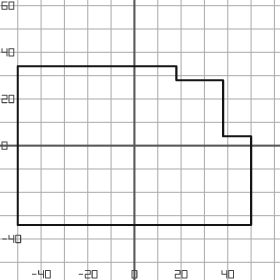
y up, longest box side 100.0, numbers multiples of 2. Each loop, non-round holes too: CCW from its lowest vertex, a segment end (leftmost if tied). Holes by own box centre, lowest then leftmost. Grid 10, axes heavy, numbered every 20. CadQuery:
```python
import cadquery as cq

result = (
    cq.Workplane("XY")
    .moveTo(-50.0, -34.0)
    .lineTo(50.0, -34.0)
    .lineTo(50.0, 4.0)
    .lineTo(38.0, 4.0)
    .lineTo(38.0, 28.0)
    .lineTo(18.0, 28.0)
    .lineTo(18.0, 34.0)
    .lineTo(-50.0, 34.0)
    .close()
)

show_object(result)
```